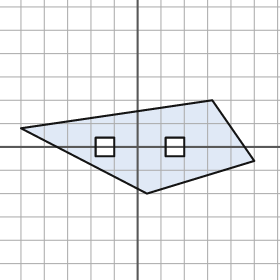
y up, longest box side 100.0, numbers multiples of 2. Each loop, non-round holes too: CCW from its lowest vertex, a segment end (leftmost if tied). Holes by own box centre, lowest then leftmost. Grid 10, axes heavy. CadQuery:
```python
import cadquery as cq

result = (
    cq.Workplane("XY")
    .moveTo(4.0, -20.0)
    .lineTo(50.0, -6.0)
    .lineTo(32.0, 20.0)
    .lineTo(-50.0, 8.0)
    .close()
    .moveTo(-18.0, -4.0)
    .lineTo(-10.0, -4.0)
    .lineTo(-10.0, 4.0)
    .lineTo(-18.0, 4.0)
    .close()
    .moveTo(12.0, -4.0)
    .lineTo(20.0, -4.0)
    .lineTo(20.0, 4.0)
    .lineTo(12.0, 4.0)
    .close()
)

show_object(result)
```